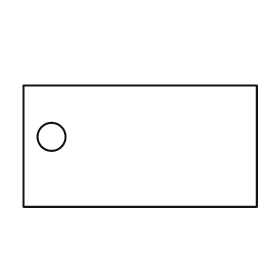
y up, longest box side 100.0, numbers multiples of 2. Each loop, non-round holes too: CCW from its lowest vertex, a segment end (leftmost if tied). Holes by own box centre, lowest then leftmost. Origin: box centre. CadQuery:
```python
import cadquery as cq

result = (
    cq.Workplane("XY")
    .moveTo(-50.0, -26.0)
    .lineTo(50.0, -26.0)
    .lineTo(50.0, 26.0)
    .lineTo(-50.0, 26.0)
    .close()
    .moveTo(-38.0, 4.0)
    .circle(6.0)
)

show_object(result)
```